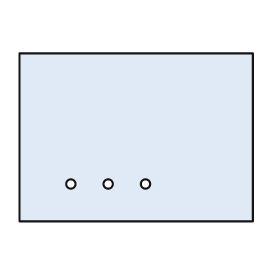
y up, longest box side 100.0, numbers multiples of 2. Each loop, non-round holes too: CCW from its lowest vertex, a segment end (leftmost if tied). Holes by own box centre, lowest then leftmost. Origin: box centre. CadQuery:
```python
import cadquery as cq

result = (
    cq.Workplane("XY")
    .moveTo(-50.0, -36.0)
    .lineTo(50.0, -36.0)
    .lineTo(50.0, 36.0)
    .lineTo(-50.0, 36.0)
    .close()
    .moveTo(-28.0, -20.0)
    .circle(2.0)
    .moveTo(-12.0, -20.0)
    .circle(2.0)
    .moveTo(4.0, -20.0)
    .circle(2.0)
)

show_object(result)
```